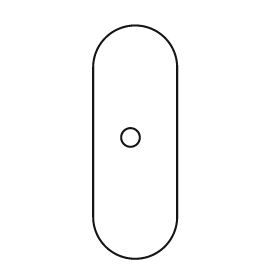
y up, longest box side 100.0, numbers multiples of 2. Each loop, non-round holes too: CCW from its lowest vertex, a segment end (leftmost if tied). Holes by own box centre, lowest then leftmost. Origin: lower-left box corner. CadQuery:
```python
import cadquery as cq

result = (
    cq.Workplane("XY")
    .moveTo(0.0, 18.0)
    .threePointArc((18.0, 0.0), (36.0, 18.0))
    .lineTo(36.0, 82.0)
    .threePointArc((18.0, 100.0), (0.0, 82.0))
    .close()
    .moveTo(16.0, 52.0)
    .circle(4.0)
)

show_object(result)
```